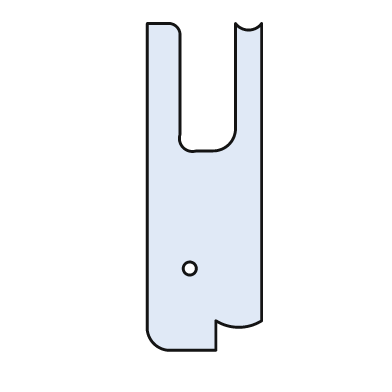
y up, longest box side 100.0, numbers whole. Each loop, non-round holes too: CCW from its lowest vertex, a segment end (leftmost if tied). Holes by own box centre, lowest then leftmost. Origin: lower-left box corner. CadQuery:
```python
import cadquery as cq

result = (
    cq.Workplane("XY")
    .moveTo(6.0, 0.0)
    .lineTo(21.0, 0.0)
    .lineTo(21.0, 9.0)
    .threePointArc((28.0, 7.0), (35.0, 9.0))
    .lineTo(35.0, 100.0)
    .threePointArc((31.0, 98.0), (27.0, 100.0))
    .lineTo(27.0, 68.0)
    .threePointArc((25.0, 63.0), (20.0, 61.0))
    .lineTo(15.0, 61.0)
    .threePointArc((11.0, 62.0), (10.0, 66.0))
    .lineTo(10.0, 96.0)
    .threePointArc((9.0, 99.0), (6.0, 100.0))
    .lineTo(0.0, 100.0)
    .lineTo(0.0, 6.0)
    .threePointArc((2.0, 2.0), (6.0, 0.0))
    .close()
    .moveTo(13.0, 25.0)
    .circle(2.0)
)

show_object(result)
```